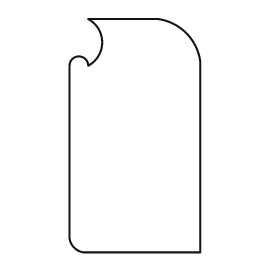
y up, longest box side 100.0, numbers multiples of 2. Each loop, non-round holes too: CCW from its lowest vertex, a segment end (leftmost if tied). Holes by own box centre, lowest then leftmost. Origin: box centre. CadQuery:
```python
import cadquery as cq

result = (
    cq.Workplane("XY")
    .moveTo(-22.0, -50.0)
    .lineTo(28.0, -50.0)
    .lineTo(28.0, 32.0)
    .threePointArc((22.0, 44.0), (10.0, 50.0))
    .lineTo(-20.0, 50.0)
    .threePointArc((-14.0, 40.0), (-20.0, 30.0))
    .threePointArc((-24.0, 34.0), (-28.0, 30.0))
    .lineTo(-28.0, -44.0)
    .threePointArc((-26.0, -48.0), (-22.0, -50.0))
    .close()
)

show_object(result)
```